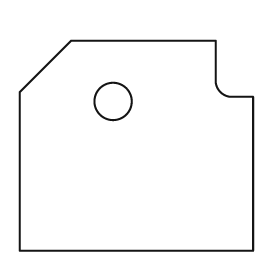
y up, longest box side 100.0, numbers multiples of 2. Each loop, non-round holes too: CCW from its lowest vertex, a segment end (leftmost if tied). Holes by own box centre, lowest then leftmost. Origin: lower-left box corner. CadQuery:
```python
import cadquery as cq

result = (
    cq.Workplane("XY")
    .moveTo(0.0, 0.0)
    .lineTo(100.0, 0.0)
    .lineTo(100.0, 66.0)
    .lineTo(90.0, 66.0)
    .threePointArc((86.0, 68.0), (84.0, 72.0))
    .lineTo(84.0, 90.0)
    .lineTo(22.0, 90.0)
    .lineTo(0.0, 68.0)
    .close()
    .moveTo(40.0, 64.0)
    .circle(8.0)
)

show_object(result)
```